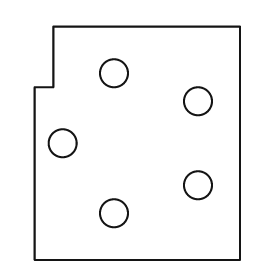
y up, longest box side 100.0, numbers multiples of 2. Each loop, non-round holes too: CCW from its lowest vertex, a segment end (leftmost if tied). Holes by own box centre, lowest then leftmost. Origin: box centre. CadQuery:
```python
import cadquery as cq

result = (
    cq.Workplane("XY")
    .moveTo(-44.0, -50.0)
    .lineTo(44.0, -50.0)
    .lineTo(44.0, 50.0)
    .lineTo(-36.0, 50.0)
    .lineTo(-36.0, 24.0)
    .lineTo(-44.0, 24.0)
    .close()
    .moveTo(-10.0, -30.0)
    .circle(6.0)
    .moveTo(26.0, -18.0)
    .circle(6.0)
    .moveTo(-32.0, 0.0)
    .circle(6.0)
    .moveTo(26.0, 18.0)
    .circle(6.0)
    .moveTo(-10.0, 30.0)
    .circle(6.0)
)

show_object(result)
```